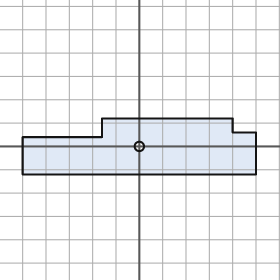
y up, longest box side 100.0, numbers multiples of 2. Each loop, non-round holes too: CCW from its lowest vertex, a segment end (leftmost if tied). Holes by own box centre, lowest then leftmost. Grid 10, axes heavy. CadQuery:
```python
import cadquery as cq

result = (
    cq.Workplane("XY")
    .moveTo(-50.0, -12.0)
    .lineTo(50.0, -12.0)
    .lineTo(50.0, 6.0)
    .lineTo(40.0, 6.0)
    .lineTo(40.0, 12.0)
    .lineTo(-16.0, 12.0)
    .lineTo(-16.0, 4.0)
    .lineTo(-50.0, 4.0)
    .close()
    .moveTo(0.0, 0.0)
    .circle(2.0)
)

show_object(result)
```